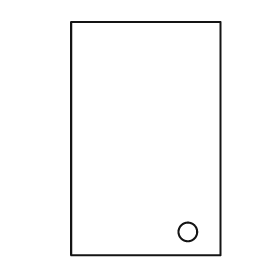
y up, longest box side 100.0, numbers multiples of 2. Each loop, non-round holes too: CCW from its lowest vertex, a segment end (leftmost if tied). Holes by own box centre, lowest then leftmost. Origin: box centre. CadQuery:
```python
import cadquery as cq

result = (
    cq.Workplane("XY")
    .moveTo(-32.0, -50.0)
    .lineTo(32.0, -50.0)
    .lineTo(32.0, 50.0)
    .lineTo(-32.0, 50.0)
    .close()
    .moveTo(18.0, -40.0)
    .circle(4.0)
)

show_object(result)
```